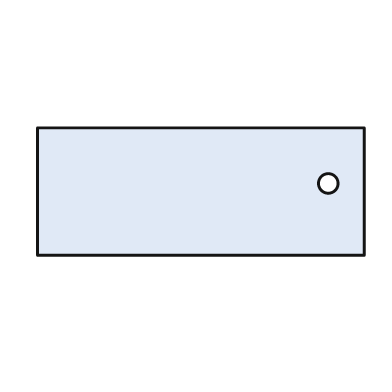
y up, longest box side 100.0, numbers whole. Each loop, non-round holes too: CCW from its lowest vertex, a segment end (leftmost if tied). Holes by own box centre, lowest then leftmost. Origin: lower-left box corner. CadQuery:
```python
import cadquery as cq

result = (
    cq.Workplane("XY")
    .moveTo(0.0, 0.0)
    .lineTo(100.0, 0.0)
    .lineTo(100.0, 39.0)
    .lineTo(0.0, 39.0)
    .close()
    .moveTo(89.0, 22.0)
    .circle(3.0)
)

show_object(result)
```